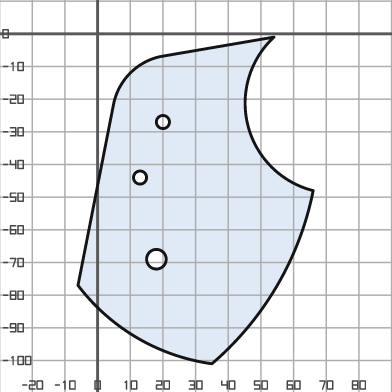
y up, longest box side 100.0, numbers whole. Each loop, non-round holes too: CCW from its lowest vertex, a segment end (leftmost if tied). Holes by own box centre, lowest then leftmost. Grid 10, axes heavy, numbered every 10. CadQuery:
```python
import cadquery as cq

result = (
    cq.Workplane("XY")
    .moveTo(35.0, -101.0)
    .threePointArc((55.0, -77.0), (66.0, -48.0))
    .threePointArc((46.0, -28.0), (54.0, -1.0))
    .lineTo(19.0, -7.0)
    .threePointArc((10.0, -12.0), (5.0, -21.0))
    .lineTo(-6.0, -77.0)
    .threePointArc((12.0, -93.0), (35.0, -101.0))
    .close()
    .moveTo(18.0, -69.0)
    .circle(3.0)
    .moveTo(13.0, -44.0)
    .circle(2.0)
    .moveTo(20.0, -27.0)
    .circle(2.0)
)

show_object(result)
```